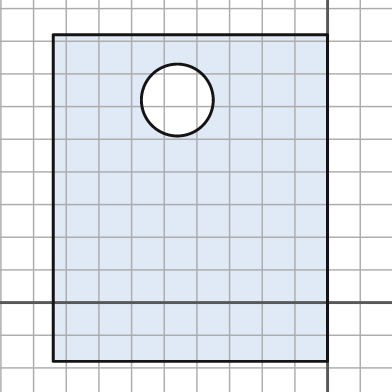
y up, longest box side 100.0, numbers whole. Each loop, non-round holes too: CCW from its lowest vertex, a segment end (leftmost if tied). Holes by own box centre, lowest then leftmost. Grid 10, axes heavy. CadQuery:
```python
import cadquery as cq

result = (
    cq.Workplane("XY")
    .moveTo(-84.0, -18.0)
    .lineTo(0.0, -18.0)
    .lineTo(0.0, 82.0)
    .lineTo(-84.0, 82.0)
    .close()
    .moveTo(-46.0, 62.0)
    .circle(11.0)
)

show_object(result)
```